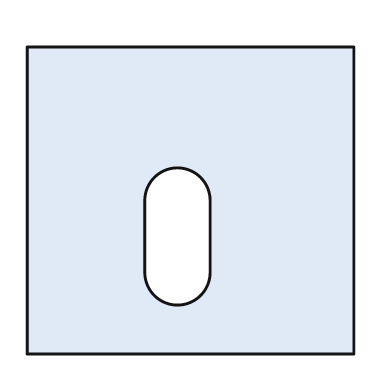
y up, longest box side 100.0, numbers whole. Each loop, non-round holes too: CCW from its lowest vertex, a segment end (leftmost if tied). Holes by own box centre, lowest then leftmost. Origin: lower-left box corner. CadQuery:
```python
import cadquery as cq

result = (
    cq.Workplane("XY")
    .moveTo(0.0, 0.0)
    .lineTo(100.0, 0.0)
    .lineTo(100.0, 94.0)
    .lineTo(0.0, 94.0)
    .close()
    .moveTo(36.0, 25.0)
    .threePointArc((46.0, 15.0), (56.0, 25.0))
    .lineTo(56.0, 47.0)
    .threePointArc((46.0, 57.0), (36.0, 47.0))
    .close()
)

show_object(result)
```